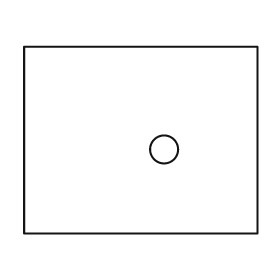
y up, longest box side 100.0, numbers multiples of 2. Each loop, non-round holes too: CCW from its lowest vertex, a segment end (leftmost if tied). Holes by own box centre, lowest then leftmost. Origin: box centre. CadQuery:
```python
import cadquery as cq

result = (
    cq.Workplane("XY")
    .moveTo(-50.0, -40.0)
    .lineTo(50.0, -40.0)
    .lineTo(50.0, 40.0)
    .lineTo(-50.0, 40.0)
    .close()
    .moveTo(10.0, -4.0)
    .circle(6.0)
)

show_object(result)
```